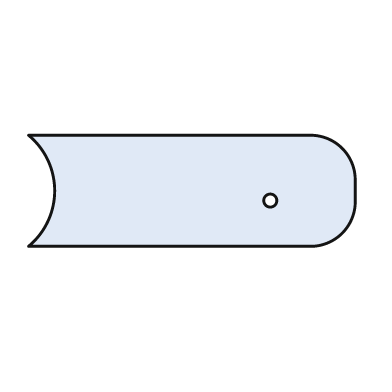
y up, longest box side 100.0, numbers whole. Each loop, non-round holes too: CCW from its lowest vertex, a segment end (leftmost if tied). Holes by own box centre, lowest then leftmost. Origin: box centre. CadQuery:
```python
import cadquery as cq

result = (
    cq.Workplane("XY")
    .moveTo(-50.0, -17.0)
    .lineTo(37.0, -17.0)
    .threePointArc((46.0, -13.0), (50.0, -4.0))
    .lineTo(50.0, 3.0)
    .threePointArc((46.0, 13.0), (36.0, 17.0))
    .lineTo(-50.0, 17.0)
    .threePointArc((-42.0, 0.0), (-50.0, -17.0))
    .close()
    .moveTo(24.0, -3.0)
    .circle(2.0)
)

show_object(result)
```